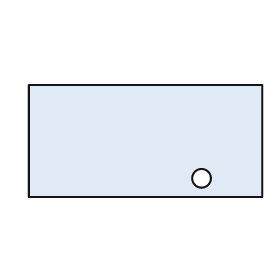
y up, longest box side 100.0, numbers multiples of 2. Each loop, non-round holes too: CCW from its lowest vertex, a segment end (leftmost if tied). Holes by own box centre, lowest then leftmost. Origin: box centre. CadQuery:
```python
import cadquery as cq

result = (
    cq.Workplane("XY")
    .moveTo(-50.0, -24.0)
    .lineTo(50.0, -24.0)
    .lineTo(50.0, 24.0)
    .lineTo(-50.0, 24.0)
    .close()
    .moveTo(24.0, -16.0)
    .circle(4.0)
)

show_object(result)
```